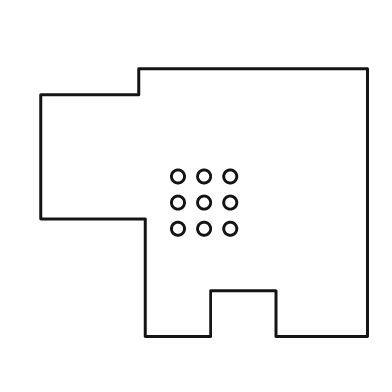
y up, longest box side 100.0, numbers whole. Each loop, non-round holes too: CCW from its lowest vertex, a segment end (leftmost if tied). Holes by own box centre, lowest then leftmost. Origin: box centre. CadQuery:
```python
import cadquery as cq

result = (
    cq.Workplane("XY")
    .moveTo(-18.0, -41.0)
    .lineTo(2.0, -41.0)
    .lineTo(2.0, -27.0)
    .lineTo(22.0, -27.0)
    .lineTo(22.0, -41.0)
    .lineTo(50.0, -41.0)
    .lineTo(50.0, 41.0)
    .lineTo(-20.0, 41.0)
    .lineTo(-20.0, 33.0)
    .lineTo(-50.0, 33.0)
    .lineTo(-50.0, -5.0)
    .lineTo(-18.0, -5.0)
    .close()
    .moveTo(-8.0, -8.0)
    .circle(2.0)
    .moveTo(0.0, -8.0)
    .circle(2.0)
    .moveTo(8.0, -8.0)
    .circle(2.0)
    .moveTo(-8.0, 0.0)
    .circle(2.0)
    .moveTo(0.0, 0.0)
    .circle(2.0)
    .moveTo(8.0, 0.0)
    .circle(2.0)
    .moveTo(-8.0, 8.0)
    .circle(2.0)
    .moveTo(0.0, 8.0)
    .circle(2.0)
    .moveTo(8.0, 8.0)
    .circle(2.0)
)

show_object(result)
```